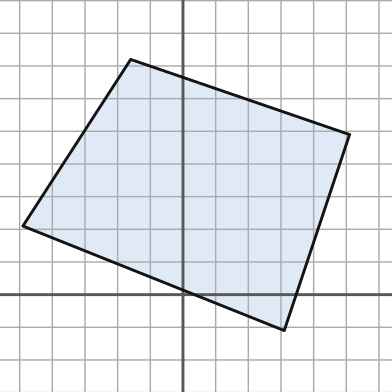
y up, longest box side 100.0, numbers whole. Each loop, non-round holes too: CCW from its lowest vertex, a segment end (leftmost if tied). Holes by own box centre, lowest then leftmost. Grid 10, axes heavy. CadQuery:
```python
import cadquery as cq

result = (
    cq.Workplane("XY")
    .moveTo(31.0, -11.0)
    .lineTo(51.0, 49.0)
    .lineTo(-16.0, 72.0)
    .lineTo(-49.0, 21.0)
    .close()
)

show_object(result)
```